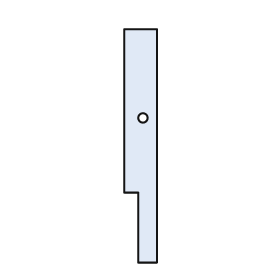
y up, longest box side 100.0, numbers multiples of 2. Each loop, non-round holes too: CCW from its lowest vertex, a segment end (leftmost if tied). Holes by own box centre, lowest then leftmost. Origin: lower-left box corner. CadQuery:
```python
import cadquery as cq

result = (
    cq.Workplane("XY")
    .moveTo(6.0, 0.0)
    .lineTo(14.0, 0.0)
    .lineTo(14.0, 100.0)
    .lineTo(0.0, 100.0)
    .lineTo(0.0, 30.0)
    .lineTo(6.0, 30.0)
    .close()
    .moveTo(8.0, 62.0)
    .circle(2.0)
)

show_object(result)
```